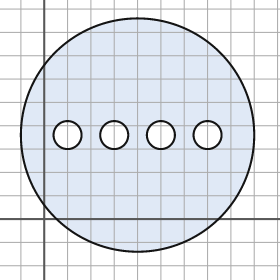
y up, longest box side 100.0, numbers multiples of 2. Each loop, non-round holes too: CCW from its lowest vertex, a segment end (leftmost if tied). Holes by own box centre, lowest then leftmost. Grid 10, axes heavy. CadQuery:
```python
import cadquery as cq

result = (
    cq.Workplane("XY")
    .moveTo(40.0, 36.0)
    .circle(50.0)
    .moveTo(10.0, 36.0)
    .circle(6.0)
    .moveTo(30.0, 36.0)
    .circle(6.0)
    .moveTo(50.0, 36.0)
    .circle(6.0)
    .moveTo(70.0, 36.0)
    .circle(6.0)
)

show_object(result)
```